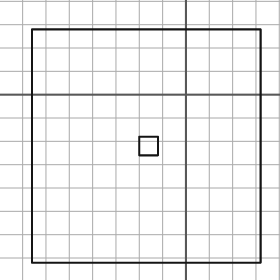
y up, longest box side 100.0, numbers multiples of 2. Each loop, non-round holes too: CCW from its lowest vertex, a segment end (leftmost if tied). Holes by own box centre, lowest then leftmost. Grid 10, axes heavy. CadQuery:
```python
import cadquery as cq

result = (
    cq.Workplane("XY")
    .moveTo(-66.0, -72.0)
    .lineTo(32.0, -72.0)
    .lineTo(32.0, 28.0)
    .lineTo(-66.0, 28.0)
    .close()
    .moveTo(-20.0, -26.0)
    .lineTo(-12.0, -26.0)
    .lineTo(-12.0, -18.0)
    .lineTo(-20.0, -18.0)
    .close()
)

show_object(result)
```